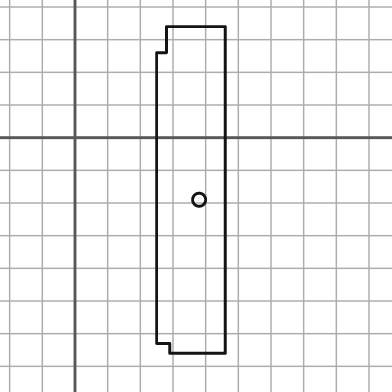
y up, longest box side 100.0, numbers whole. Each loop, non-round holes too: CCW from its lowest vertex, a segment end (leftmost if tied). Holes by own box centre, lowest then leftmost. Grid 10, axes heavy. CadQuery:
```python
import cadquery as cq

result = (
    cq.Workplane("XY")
    .moveTo(29.0, -66.0)
    .lineTo(46.0, -66.0)
    .lineTo(46.0, 34.0)
    .lineTo(28.0, 34.0)
    .lineTo(28.0, 26.0)
    .lineTo(25.0, 26.0)
    .lineTo(25.0, -63.0)
    .lineTo(29.0, -63.0)
    .close()
    .moveTo(38.0, -19.0)
    .circle(2.0)
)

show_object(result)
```